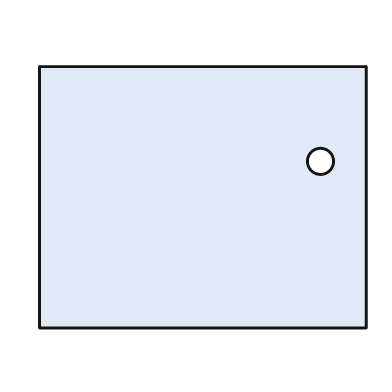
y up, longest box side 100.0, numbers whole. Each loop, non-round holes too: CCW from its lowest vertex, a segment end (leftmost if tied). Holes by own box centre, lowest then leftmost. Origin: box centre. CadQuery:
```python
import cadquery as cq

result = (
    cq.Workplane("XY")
    .moveTo(-50.0, -40.0)
    .lineTo(50.0, -40.0)
    .lineTo(50.0, 40.0)
    .lineTo(-50.0, 40.0)
    .close()
    .moveTo(36.0, 11.0)
    .circle(4.0)
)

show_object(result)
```